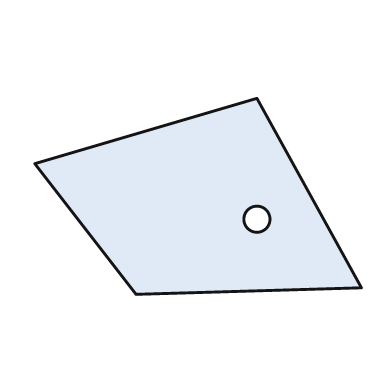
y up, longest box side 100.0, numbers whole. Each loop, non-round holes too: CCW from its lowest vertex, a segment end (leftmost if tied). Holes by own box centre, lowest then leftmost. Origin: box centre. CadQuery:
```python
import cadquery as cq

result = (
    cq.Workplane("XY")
    .moveTo(-19.0, -30.0)
    .lineTo(50.0, -28.0)
    .lineTo(18.0, 30.0)
    .lineTo(-50.0, 10.0)
    .close()
    .moveTo(18.0, -7.0)
    .circle(4.0)
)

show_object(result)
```